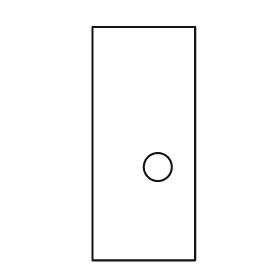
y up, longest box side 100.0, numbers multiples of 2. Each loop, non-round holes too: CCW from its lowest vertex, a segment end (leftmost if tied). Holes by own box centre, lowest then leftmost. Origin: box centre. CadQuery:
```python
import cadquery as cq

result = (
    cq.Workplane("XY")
    .moveTo(-22.0, -50.0)
    .lineTo(22.0, -50.0)
    .lineTo(22.0, 50.0)
    .lineTo(-22.0, 50.0)
    .close()
    .moveTo(6.0, -10.0)
    .circle(6.0)
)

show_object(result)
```